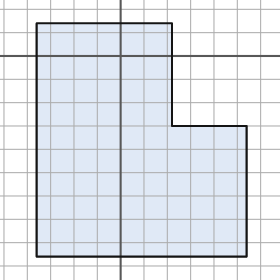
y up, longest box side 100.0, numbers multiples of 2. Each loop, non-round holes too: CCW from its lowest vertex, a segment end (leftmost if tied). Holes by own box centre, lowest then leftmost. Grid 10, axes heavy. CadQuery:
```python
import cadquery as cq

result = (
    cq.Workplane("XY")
    .moveTo(-36.0, -86.0)
    .lineTo(54.0, -86.0)
    .lineTo(54.0, -30.0)
    .lineTo(22.0, -30.0)
    .lineTo(22.0, 14.0)
    .lineTo(-36.0, 14.0)
    .close()
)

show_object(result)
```